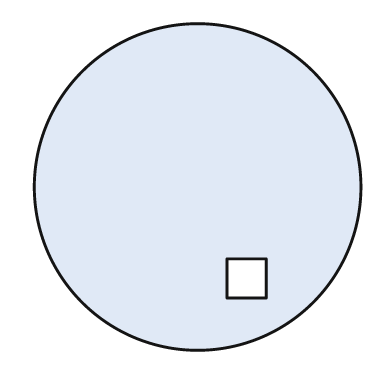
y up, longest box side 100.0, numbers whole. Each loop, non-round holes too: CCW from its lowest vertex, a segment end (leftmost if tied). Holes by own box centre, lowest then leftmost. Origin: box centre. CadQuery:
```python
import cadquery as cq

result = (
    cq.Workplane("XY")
    .moveTo(0.0, 0.0)
    .circle(50.0)
    .moveTo(9.0, -34.0)
    .lineTo(21.0, -34.0)
    .lineTo(21.0, -22.0)
    .lineTo(9.0, -22.0)
    .close()
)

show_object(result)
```